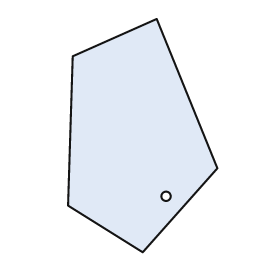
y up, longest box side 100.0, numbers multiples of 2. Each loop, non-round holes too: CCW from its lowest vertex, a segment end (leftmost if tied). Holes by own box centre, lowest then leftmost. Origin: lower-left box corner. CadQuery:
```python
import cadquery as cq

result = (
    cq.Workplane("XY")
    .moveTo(32.0, 0.0)
    .lineTo(64.0, 36.0)
    .lineTo(38.0, 100.0)
    .lineTo(2.0, 84.0)
    .lineTo(0.0, 20.0)
    .close()
    .moveTo(42.0, 24.0)
    .circle(2.0)
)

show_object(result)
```